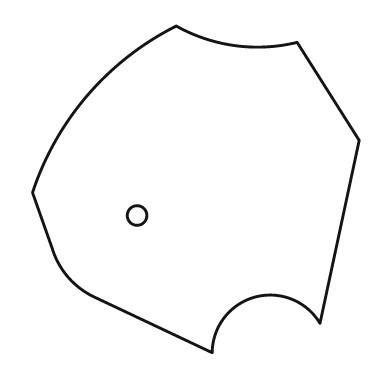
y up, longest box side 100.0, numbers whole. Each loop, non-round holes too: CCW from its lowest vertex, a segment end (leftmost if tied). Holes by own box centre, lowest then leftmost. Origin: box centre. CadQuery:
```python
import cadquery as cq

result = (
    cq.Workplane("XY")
    .moveTo(5.0, -50.0)
    .threePointArc((18.0, -33.0), (38.0, -41.0))
    .lineTo(50.0, 15.0)
    .lineTo(31.0, 45.0)
    .threePointArc((12.0, 44.0), (-6.0, 50.0))
    .threePointArc((-33.0, 29.0), (-50.0, -1.0))
    .lineTo(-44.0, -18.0)
    .threePointArc((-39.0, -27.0), (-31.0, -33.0))
    .close()
    .moveTo(-18.0, -8.0)
    .circle(3.0)
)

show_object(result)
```